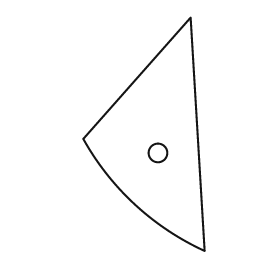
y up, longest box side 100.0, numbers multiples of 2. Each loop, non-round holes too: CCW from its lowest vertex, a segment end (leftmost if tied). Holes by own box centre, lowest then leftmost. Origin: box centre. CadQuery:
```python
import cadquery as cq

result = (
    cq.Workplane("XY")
    .moveTo(26.0, -50.0)
    .lineTo(20.0, 50.0)
    .lineTo(-26.0, -2.0)
    .threePointArc((-4.0, -30.0), (26.0, -50.0))
    .close()
    .moveTo(6.0, -8.0)
    .circle(4.0)
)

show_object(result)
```